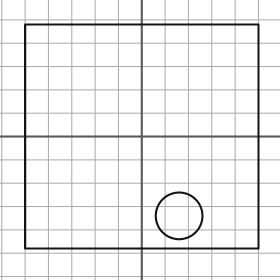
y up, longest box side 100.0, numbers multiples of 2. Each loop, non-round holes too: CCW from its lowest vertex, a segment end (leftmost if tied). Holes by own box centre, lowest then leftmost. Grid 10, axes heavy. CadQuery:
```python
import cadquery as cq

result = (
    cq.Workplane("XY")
    .moveTo(-50.0, -48.0)
    .lineTo(50.0, -48.0)
    .lineTo(50.0, 48.0)
    .lineTo(-50.0, 48.0)
    .close()
    .moveTo(16.0, -34.0)
    .circle(10.0)
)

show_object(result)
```